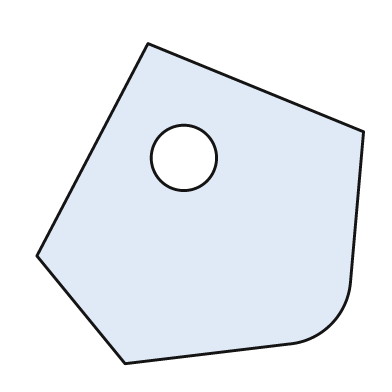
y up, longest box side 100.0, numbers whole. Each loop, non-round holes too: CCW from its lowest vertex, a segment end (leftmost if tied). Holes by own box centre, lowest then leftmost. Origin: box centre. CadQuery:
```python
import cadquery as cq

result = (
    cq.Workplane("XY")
    .moveTo(-23.0, -49.0)
    .lineTo(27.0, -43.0)
    .threePointArc((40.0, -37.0), (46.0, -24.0))
    .lineTo(50.0, 22.0)
    .lineTo(-16.0, 49.0)
    .lineTo(-50.0, -16.0)
    .close()
    .moveTo(-5.0, 14.0)
    .circle(10.0)
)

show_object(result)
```